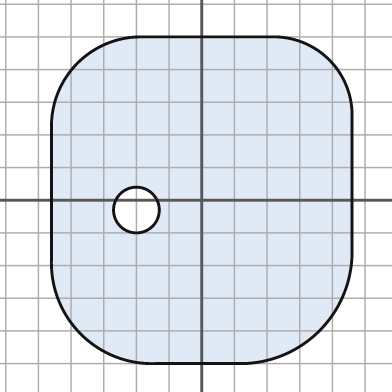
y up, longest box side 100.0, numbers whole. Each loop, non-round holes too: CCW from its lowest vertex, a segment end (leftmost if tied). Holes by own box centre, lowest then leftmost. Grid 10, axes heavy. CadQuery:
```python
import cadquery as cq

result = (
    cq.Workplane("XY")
    .moveTo(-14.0, -50.0)
    .lineTo(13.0, -50.0)
    .threePointArc((36.0, -40.0), (46.0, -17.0))
    .lineTo(46.0, 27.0)
    .threePointArc((39.0, 43.0), (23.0, 50.0))
    .lineTo(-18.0, 50.0)
    .threePointArc((-38.0, 42.0), (-46.0, 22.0))
    .lineTo(-46.0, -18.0)
    .threePointArc((-37.0, -41.0), (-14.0, -50.0))
    .close()
    .moveTo(-20.0, -3.0)
    .circle(7.0)
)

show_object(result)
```